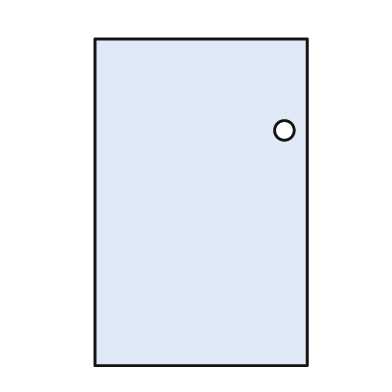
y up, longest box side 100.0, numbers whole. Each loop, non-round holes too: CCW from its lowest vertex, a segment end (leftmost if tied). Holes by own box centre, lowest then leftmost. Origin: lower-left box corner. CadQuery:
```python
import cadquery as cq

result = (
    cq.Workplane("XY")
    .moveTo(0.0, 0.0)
    .lineTo(65.0, 0.0)
    .lineTo(65.0, 100.0)
    .lineTo(0.0, 100.0)
    .close()
    .moveTo(58.0, 72.0)
    .circle(3.0)
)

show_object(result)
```